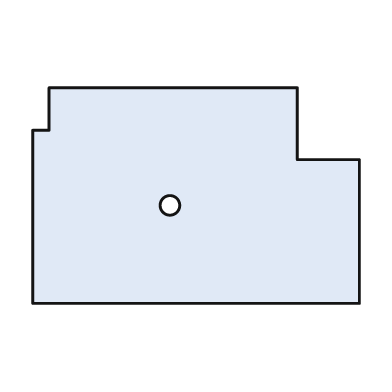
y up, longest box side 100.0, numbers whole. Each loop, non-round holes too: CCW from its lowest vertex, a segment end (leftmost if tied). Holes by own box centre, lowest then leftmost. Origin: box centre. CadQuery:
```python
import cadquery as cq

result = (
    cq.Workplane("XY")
    .moveTo(-50.0, -33.0)
    .lineTo(50.0, -33.0)
    .lineTo(50.0, 11.0)
    .lineTo(31.0, 11.0)
    .lineTo(31.0, 33.0)
    .lineTo(-45.0, 33.0)
    .lineTo(-45.0, 20.0)
    .lineTo(-50.0, 20.0)
    .close()
    .moveTo(-8.0, -3.0)
    .circle(3.0)
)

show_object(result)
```